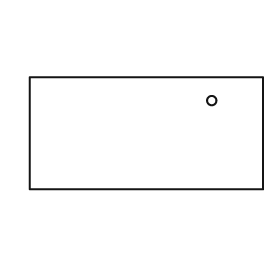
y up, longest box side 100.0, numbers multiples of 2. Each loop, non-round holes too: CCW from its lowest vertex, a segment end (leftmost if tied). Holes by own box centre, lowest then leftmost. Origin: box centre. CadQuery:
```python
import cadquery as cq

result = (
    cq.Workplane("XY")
    .moveTo(-50.0, -24.0)
    .lineTo(50.0, -24.0)
    .lineTo(50.0, 24.0)
    .lineTo(-50.0, 24.0)
    .close()
    .moveTo(28.0, 14.0)
    .circle(2.0)
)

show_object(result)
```